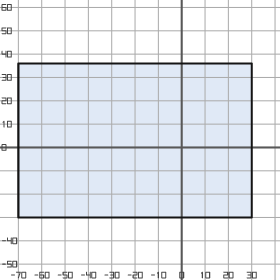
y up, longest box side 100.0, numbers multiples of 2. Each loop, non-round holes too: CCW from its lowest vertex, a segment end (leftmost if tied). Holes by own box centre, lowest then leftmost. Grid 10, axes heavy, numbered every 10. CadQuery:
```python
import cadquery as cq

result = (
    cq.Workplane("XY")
    .moveTo(-70.0, -30.0)
    .lineTo(30.0, -30.0)
    .lineTo(30.0, 36.0)
    .lineTo(-70.0, 36.0)
    .close()
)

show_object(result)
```